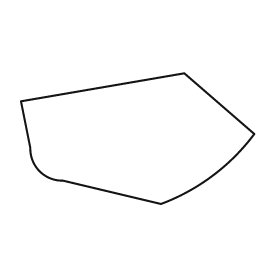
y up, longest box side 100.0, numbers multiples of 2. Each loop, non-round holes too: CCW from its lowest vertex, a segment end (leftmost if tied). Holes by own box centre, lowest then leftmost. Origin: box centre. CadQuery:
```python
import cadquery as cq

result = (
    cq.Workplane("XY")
    .moveTo(10.0, -28.0)
    .threePointArc((32.0, -16.0), (50.0, 2.0))
    .lineTo(20.0, 28.0)
    .lineTo(-50.0, 16.0)
    .lineTo(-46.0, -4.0)
    .threePointArc((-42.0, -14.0), (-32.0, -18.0))
    .close()
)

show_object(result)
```